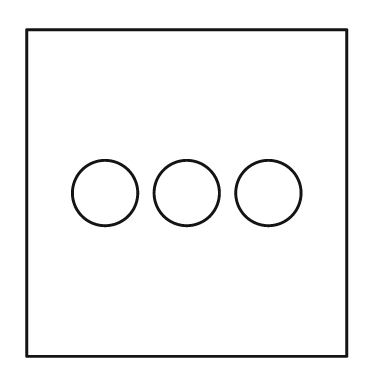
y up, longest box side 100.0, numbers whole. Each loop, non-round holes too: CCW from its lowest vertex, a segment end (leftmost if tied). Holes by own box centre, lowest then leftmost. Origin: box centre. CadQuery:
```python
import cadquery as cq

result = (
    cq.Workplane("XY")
    .moveTo(-49.0, -50.0)
    .lineTo(49.0, -50.0)
    .lineTo(49.0, 50.0)
    .lineTo(-49.0, 50.0)
    .close()
    .moveTo(-25.0, 0.0)
    .circle(10.0)
    .moveTo(0.0, 0.0)
    .circle(10.0)
    .moveTo(25.0, 0.0)
    .circle(10.0)
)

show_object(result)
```